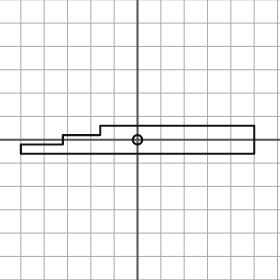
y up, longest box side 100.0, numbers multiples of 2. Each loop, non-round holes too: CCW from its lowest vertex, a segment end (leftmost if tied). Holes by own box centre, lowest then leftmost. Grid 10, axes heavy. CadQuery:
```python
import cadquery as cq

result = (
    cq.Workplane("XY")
    .moveTo(-50.0, -6.0)
    .lineTo(50.0, -6.0)
    .lineTo(50.0, 6.0)
    .lineTo(-16.0, 6.0)
    .lineTo(-16.0, 2.0)
    .lineTo(-32.0, 2.0)
    .lineTo(-32.0, -2.0)
    .lineTo(-50.0, -2.0)
    .close()
    .moveTo(0.0, 0.0)
    .circle(2.0)
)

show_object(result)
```